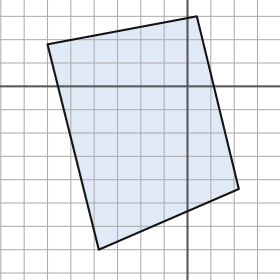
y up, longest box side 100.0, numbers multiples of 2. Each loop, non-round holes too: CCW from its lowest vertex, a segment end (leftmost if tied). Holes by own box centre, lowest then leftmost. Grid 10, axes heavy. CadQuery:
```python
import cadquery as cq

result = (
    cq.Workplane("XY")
    .moveTo(-38.0, -70.0)
    .lineTo(22.0, -44.0)
    .lineTo(4.0, 30.0)
    .lineTo(-60.0, 18.0)
    .close()
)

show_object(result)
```